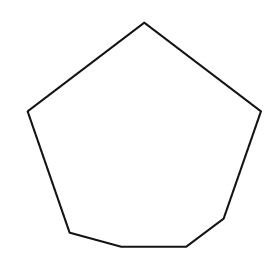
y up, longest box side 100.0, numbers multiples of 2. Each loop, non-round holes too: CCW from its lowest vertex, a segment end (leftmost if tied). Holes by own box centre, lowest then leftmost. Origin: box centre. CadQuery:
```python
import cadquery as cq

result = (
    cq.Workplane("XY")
    .moveTo(-10.0, -48.0)
    .lineTo(18.0, -48.0)
    .lineTo(34.0, -36.0)
    .lineTo(50.0, 10.0)
    .lineTo(0.0, 48.0)
    .lineTo(-50.0, 10.0)
    .lineTo(-32.0, -42.0)
    .close()
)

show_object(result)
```